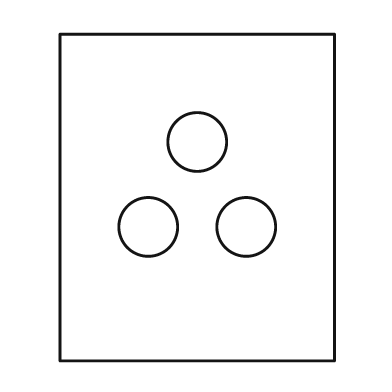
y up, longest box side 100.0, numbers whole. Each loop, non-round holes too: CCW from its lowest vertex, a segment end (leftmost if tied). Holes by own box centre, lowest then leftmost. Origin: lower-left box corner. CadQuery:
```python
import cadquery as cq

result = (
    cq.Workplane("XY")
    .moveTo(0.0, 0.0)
    .lineTo(84.0, 0.0)
    .lineTo(84.0, 100.0)
    .lineTo(0.0, 100.0)
    .close()
    .moveTo(27.0, 41.0)
    .circle(9.0)
    .moveTo(57.0, 41.0)
    .circle(9.0)
    .moveTo(42.0, 67.0)
    .circle(9.0)
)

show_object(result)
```